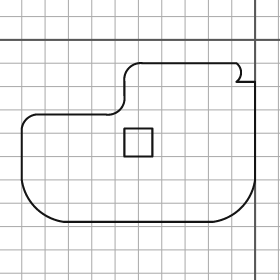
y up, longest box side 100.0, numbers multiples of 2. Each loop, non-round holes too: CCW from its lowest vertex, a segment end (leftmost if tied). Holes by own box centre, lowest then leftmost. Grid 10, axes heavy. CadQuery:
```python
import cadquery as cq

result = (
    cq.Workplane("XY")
    .moveTo(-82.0, -78.0)
    .lineTo(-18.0, -78.0)
    .threePointArc((-6.0, -72.0), (0.0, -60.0))
    .lineTo(0.0, -18.0)
    .lineTo(-8.0, -18.0)
    .threePointArc((-6.0, -14.0), (-8.0, -10.0))
    .lineTo(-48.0, -10.0)
    .threePointArc((-54.0, -12.0), (-56.0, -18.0))
    .lineTo(-56.0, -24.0)
    .threePointArc((-58.0, -30.0), (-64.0, -32.0))
    .lineTo(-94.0, -32.0)
    .threePointArc((-98.0, -34.0), (-100.0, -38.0))
    .lineTo(-100.0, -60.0)
    .threePointArc((-94.0, -72.0), (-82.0, -78.0))
    .close()
    .moveTo(-56.0, -50.0)
    .lineTo(-44.0, -50.0)
    .lineTo(-44.0, -38.0)
    .lineTo(-56.0, -38.0)
    .close()
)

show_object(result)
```